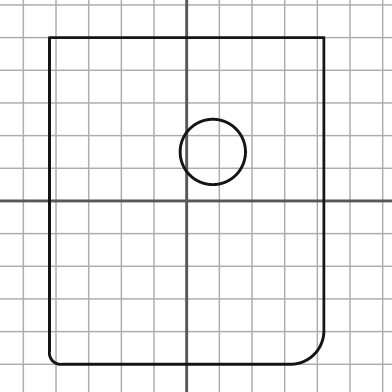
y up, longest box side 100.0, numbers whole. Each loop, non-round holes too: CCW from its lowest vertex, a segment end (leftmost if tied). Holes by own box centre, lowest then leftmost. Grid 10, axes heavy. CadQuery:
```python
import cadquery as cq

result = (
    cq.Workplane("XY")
    .moveTo(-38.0, -50.0)
    .lineTo(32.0, -50.0)
    .threePointArc((39.0, -47.0), (42.0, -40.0))
    .lineTo(42.0, 50.0)
    .lineTo(-42.0, 50.0)
    .lineTo(-42.0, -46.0)
    .threePointArc((-41.0, -49.0), (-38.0, -50.0))
    .close()
    .moveTo(8.0, 15.0)
    .circle(10.0)
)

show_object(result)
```